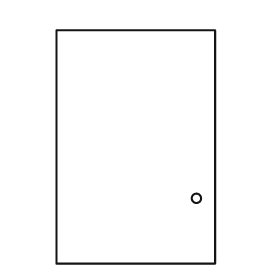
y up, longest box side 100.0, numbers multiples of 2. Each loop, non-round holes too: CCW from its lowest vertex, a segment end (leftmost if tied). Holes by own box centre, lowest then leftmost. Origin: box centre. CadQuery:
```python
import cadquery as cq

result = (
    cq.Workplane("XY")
    .moveTo(-34.0, -50.0)
    .lineTo(34.0, -50.0)
    .lineTo(34.0, 50.0)
    .lineTo(-34.0, 50.0)
    .close()
    .moveTo(26.0, -22.0)
    .circle(2.0)
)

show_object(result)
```